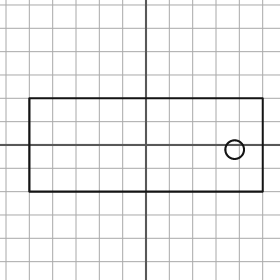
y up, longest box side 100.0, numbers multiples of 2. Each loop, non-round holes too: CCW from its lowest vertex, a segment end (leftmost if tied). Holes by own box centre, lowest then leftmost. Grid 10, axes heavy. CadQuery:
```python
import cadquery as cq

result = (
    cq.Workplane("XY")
    .moveTo(-50.0, -20.0)
    .lineTo(50.0, -20.0)
    .lineTo(50.0, 20.0)
    .lineTo(-50.0, 20.0)
    .close()
    .moveTo(38.0, -2.0)
    .circle(4.0)
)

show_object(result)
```